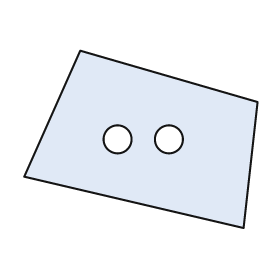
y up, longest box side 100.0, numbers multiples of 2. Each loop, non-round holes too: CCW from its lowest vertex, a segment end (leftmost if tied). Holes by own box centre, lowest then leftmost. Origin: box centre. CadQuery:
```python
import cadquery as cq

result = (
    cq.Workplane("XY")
    .moveTo(44.0, -38.0)
    .lineTo(50.0, 16.0)
    .lineTo(-26.0, 38.0)
    .lineTo(-50.0, -16.0)
    .close()
    .moveTo(-10.0, 0.0)
    .circle(6.0)
    .moveTo(12.0, 0.0)
    .circle(6.0)
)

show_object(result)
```